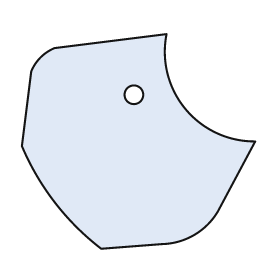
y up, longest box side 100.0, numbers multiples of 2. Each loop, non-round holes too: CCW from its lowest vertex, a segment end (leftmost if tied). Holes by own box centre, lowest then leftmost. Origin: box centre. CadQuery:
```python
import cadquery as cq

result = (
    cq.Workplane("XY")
    .moveTo(-16.0, -46.0)
    .lineTo(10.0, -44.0)
    .threePointArc((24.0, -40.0), (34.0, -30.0))
    .lineTo(50.0, 0.0)
    .threePointArc((20.0, 14.0), (12.0, 46.0))
    .lineTo(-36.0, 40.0)
    .threePointArc((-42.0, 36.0), (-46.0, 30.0))
    .lineTo(-50.0, -2.0)
    .threePointArc((-36.0, -26.0), (-16.0, -46.0))
    .close()
    .moveTo(-2.0, 20.0)
    .circle(4.0)
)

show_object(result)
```